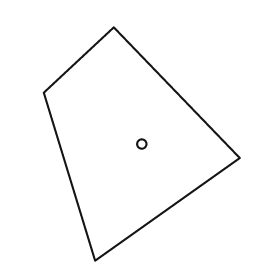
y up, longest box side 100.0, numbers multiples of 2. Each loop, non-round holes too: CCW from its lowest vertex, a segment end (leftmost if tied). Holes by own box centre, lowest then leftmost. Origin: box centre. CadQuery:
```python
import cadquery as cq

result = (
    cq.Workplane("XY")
    .moveTo(-20.0, -50.0)
    .lineTo(42.0, -6.0)
    .lineTo(-12.0, 50.0)
    .lineTo(-42.0, 22.0)
    .close()
    .moveTo(0.0, 0.0)
    .circle(2.0)
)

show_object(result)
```